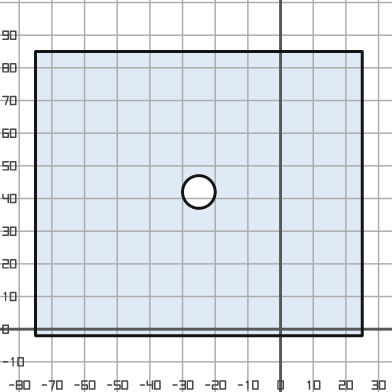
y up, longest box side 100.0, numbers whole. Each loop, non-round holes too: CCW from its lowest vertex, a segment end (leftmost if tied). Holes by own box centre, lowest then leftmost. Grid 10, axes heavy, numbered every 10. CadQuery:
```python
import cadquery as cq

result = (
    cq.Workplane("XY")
    .moveTo(-75.0, -2.0)
    .lineTo(25.0, -2.0)
    .lineTo(25.0, 85.0)
    .lineTo(-75.0, 85.0)
    .close()
    .moveTo(-25.0, 42.0)
    .circle(5.0)
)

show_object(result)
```